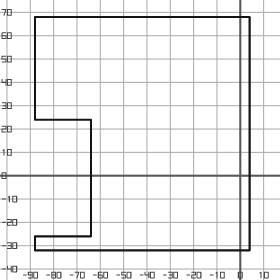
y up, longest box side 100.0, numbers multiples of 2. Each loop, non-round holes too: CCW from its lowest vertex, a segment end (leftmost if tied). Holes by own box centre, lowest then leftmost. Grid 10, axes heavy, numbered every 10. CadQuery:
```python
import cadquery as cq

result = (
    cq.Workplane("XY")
    .moveTo(-88.0, -32.0)
    .lineTo(4.0, -32.0)
    .lineTo(4.0, 68.0)
    .lineTo(-88.0, 68.0)
    .lineTo(-88.0, 24.0)
    .lineTo(-64.0, 24.0)
    .lineTo(-64.0, -26.0)
    .lineTo(-88.0, -26.0)
    .close()
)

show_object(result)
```